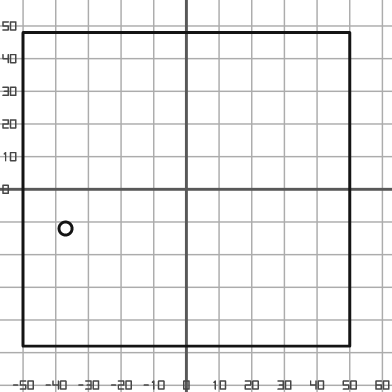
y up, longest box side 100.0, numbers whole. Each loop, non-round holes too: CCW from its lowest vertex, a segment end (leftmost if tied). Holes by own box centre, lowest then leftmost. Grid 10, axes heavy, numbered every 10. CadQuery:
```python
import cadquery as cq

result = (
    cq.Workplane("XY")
    .moveTo(-50.0, -48.0)
    .lineTo(50.0, -48.0)
    .lineTo(50.0, 48.0)
    .lineTo(-50.0, 48.0)
    .close()
    .moveTo(-37.0, -12.0)
    .circle(2.0)
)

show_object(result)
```